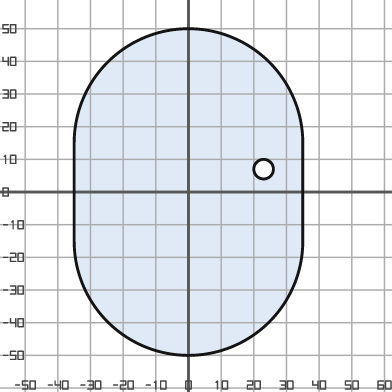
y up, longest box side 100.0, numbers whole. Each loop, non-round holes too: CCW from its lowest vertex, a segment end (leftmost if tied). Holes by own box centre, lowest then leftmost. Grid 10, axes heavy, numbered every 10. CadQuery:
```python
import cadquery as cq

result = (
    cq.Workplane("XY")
    .moveTo(-35.0, -15.0)
    .threePointArc((0.0, -50.0), (35.0, -15.0))
    .lineTo(35.0, 15.0)
    .threePointArc((0.0, 50.0), (-35.0, 15.0))
    .close()
    .moveTo(23.0, 7.0)
    .circle(3.0)
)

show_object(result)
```